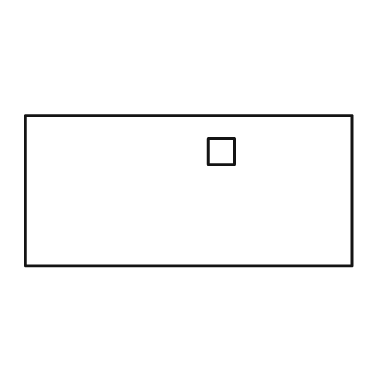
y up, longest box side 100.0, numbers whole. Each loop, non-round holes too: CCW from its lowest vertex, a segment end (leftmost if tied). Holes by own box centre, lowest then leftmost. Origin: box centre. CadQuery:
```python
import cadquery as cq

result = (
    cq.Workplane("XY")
    .moveTo(-50.0, -23.0)
    .lineTo(50.0, -23.0)
    .lineTo(50.0, 23.0)
    .lineTo(-50.0, 23.0)
    .close()
    .moveTo(6.0, 8.0)
    .lineTo(14.0, 8.0)
    .lineTo(14.0, 16.0)
    .lineTo(6.0, 16.0)
    .close()
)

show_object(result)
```